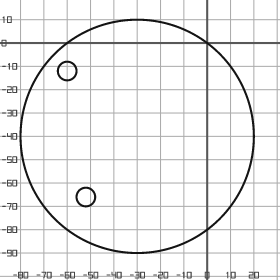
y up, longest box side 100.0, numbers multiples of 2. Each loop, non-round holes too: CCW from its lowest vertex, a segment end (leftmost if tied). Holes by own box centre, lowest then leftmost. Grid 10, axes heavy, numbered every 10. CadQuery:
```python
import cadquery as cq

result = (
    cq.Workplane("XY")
    .moveTo(-30.0, -40.0)
    .circle(50.0)
    .moveTo(-52.0, -66.0)
    .circle(4.0)
    .moveTo(-60.0, -12.0)
    .circle(4.0)
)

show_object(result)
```